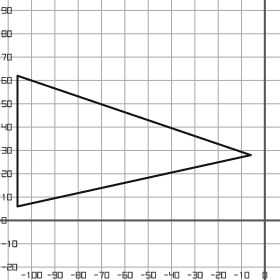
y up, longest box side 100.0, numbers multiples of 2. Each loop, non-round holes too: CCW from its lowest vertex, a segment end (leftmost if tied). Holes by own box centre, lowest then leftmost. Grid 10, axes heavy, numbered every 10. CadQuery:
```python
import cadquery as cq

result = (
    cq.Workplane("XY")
    .moveTo(-106.0, 6.0)
    .lineTo(-6.0, 28.0)
    .lineTo(-106.0, 62.0)
    .close()
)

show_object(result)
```